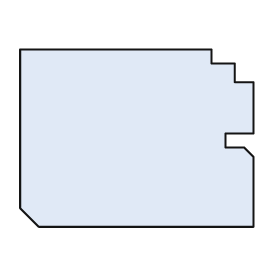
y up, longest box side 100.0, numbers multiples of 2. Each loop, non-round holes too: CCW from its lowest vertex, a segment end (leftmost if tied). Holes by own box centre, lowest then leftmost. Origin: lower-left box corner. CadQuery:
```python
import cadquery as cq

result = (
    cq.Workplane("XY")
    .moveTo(8.0, 0.0)
    .lineTo(100.0, 0.0)
    .lineTo(100.0, 30.0)
    .lineTo(96.0, 34.0)
    .lineTo(88.0, 34.0)
    .lineTo(88.0, 40.0)
    .lineTo(100.0, 40.0)
    .lineTo(100.0, 62.0)
    .lineTo(92.0, 62.0)
    .lineTo(92.0, 70.0)
    .lineTo(82.0, 70.0)
    .lineTo(82.0, 76.0)
    .lineTo(0.0, 76.0)
    .lineTo(0.0, 8.0)
    .close()
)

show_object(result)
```